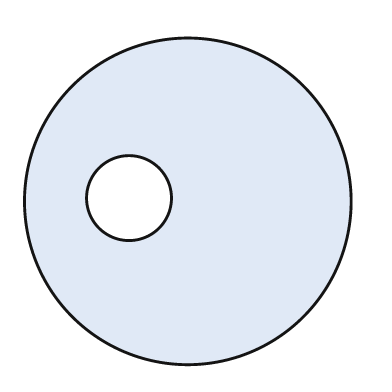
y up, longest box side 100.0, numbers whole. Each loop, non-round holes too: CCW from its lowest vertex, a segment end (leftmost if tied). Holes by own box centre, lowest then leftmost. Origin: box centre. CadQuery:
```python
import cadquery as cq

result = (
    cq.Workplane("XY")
    .moveTo(0.0, 0.0)
    .circle(50.0)
    .moveTo(-18.0, 1.0)
    .circle(13.0)
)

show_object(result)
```